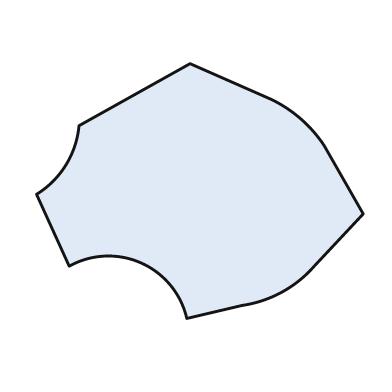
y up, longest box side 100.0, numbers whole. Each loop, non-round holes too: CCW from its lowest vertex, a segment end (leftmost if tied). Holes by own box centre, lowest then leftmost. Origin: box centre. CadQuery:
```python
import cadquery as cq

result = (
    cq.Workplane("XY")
    .moveTo(-4.0, -39.0)
    .lineTo(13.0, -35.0)
    .threePointArc((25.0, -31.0), (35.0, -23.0))
    .lineTo(50.0, -7.0)
    .lineTo(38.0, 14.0)
    .threePointArc((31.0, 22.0), (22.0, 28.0))
    .lineTo(-3.0, 39.0)
    .lineTo(-37.0, 20.0)
    .threePointArc((-41.0, 8.0), (-50.0, -1.0))
    .lineTo(-40.0, -23.0)
    .threePointArc((-18.0, -22.0), (-4.0, -39.0))
    .close()
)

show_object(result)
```